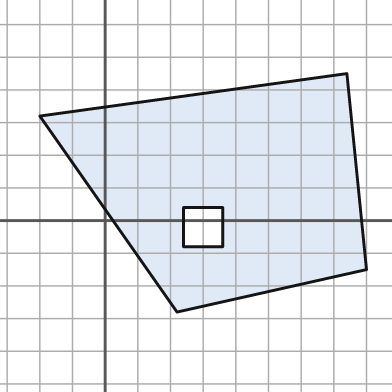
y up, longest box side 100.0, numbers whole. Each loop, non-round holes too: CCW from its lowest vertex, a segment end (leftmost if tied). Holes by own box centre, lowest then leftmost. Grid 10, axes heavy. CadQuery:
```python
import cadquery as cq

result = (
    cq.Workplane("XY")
    .moveTo(22.0, -28.0)
    .lineTo(80.0, -15.0)
    .lineTo(74.0, 45.0)
    .lineTo(-20.0, 32.0)
    .close()
    .moveTo(24.0, -8.0)
    .lineTo(36.0, -8.0)
    .lineTo(36.0, 4.0)
    .lineTo(24.0, 4.0)
    .close()
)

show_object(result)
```